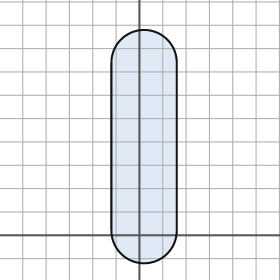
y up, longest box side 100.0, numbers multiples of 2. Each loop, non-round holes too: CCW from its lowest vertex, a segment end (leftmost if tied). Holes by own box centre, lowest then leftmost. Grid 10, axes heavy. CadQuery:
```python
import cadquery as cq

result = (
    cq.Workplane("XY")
    .moveTo(-12.0, 2.0)
    .threePointArc((2.0, -12.0), (16.0, 2.0))
    .lineTo(16.0, 74.0)
    .threePointArc((2.0, 88.0), (-12.0, 74.0))
    .close()
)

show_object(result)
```